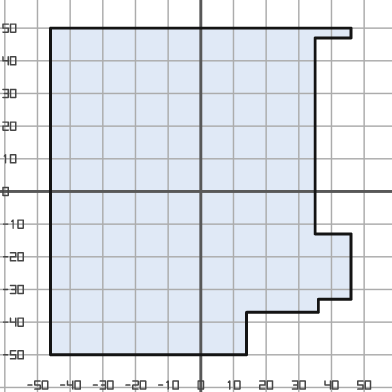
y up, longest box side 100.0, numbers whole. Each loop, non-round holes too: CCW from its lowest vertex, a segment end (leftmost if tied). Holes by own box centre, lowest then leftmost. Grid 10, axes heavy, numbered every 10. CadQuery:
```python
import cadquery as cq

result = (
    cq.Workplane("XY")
    .moveTo(-46.0, -50.0)
    .lineTo(14.0, -50.0)
    .lineTo(14.0, -37.0)
    .lineTo(36.0, -37.0)
    .lineTo(36.0, -33.0)
    .lineTo(46.0, -33.0)
    .lineTo(46.0, -13.0)
    .lineTo(35.0, -13.0)
    .lineTo(35.0, 47.0)
    .lineTo(46.0, 47.0)
    .lineTo(46.0, 50.0)
    .lineTo(-46.0, 50.0)
    .close()
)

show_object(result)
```